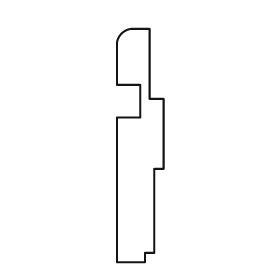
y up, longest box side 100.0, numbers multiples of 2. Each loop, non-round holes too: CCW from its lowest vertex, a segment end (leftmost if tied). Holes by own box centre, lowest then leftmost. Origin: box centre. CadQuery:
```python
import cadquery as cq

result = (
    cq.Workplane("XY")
    .moveTo(-10.0, -50.0)
    .lineTo(2.0, -50.0)
    .lineTo(2.0, -46.0)
    .lineTo(6.0, -46.0)
    .lineTo(6.0, -10.0)
    .lineTo(10.0, -10.0)
    .lineTo(10.0, 20.0)
    .lineTo(4.0, 20.0)
    .lineTo(4.0, 50.0)
    .lineTo(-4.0, 50.0)
    .threePointArc((-8.0, 48.0), (-10.0, 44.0))
    .lineTo(-10.0, 26.0)
    .lineTo(0.0, 26.0)
    .lineTo(0.0, 12.0)
    .lineTo(-10.0, 12.0)
    .close()
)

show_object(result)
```